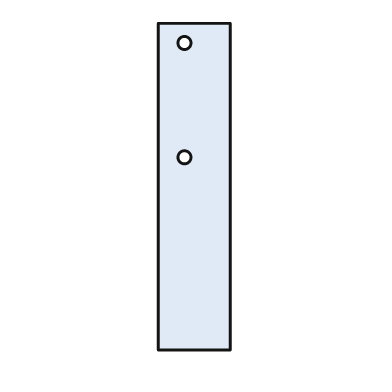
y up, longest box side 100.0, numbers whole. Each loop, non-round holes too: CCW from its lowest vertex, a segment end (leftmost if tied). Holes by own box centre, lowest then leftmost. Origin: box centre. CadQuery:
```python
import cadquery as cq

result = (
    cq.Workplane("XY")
    .moveTo(-11.0, -50.0)
    .lineTo(11.0, -50.0)
    .lineTo(11.0, 50.0)
    .lineTo(-11.0, 50.0)
    .close()
    .moveTo(-3.0, 9.0)
    .circle(2.0)
    .moveTo(-3.0, 44.0)
    .circle(2.0)
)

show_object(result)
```